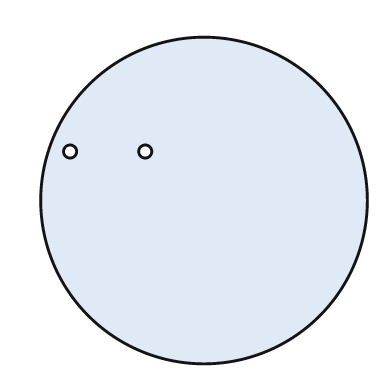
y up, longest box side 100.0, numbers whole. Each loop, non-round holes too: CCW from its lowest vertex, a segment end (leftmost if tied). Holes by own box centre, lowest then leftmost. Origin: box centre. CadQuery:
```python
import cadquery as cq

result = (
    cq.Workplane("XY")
    .moveTo(0.0, 0.0)
    .circle(50.0)
    .moveTo(-41.0, 15.0)
    .circle(2.0)
    .moveTo(-18.0, 15.0)
    .circle(2.0)
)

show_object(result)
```